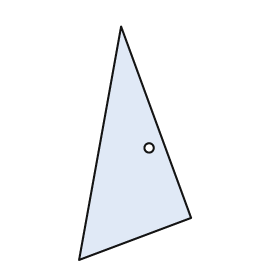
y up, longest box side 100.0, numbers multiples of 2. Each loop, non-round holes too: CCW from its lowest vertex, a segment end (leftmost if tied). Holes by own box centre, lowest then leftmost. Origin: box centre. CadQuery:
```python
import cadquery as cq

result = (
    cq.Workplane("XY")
    .moveTo(-24.0, -50.0)
    .lineTo(24.0, -32.0)
    .lineTo(-6.0, 50.0)
    .close()
    .moveTo(6.0, -2.0)
    .circle(2.0)
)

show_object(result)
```